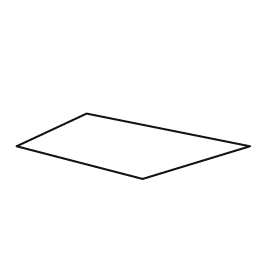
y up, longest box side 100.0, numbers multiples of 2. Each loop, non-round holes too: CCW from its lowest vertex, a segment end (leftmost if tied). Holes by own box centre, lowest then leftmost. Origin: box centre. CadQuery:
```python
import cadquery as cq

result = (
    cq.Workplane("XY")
    .moveTo(4.0, -14.0)
    .lineTo(50.0, 0.0)
    .lineTo(-20.0, 14.0)
    .lineTo(-50.0, 0.0)
    .close()
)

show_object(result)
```